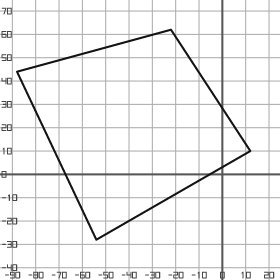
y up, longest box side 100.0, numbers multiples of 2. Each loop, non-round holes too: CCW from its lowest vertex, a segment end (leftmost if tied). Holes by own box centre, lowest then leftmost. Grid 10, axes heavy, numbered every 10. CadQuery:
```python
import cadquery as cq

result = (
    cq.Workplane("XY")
    .moveTo(-54.0, -28.0)
    .lineTo(12.0, 10.0)
    .lineTo(-22.0, 62.0)
    .lineTo(-88.0, 44.0)
    .close()
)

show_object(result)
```